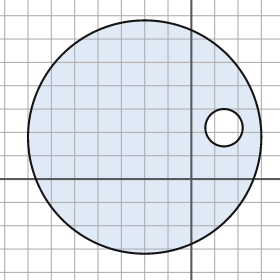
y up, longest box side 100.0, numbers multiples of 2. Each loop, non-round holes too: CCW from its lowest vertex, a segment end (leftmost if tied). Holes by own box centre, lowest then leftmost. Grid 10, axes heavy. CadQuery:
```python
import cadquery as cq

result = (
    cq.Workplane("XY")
    .moveTo(-20.0, 18.0)
    .circle(50.0)
    .moveTo(14.0, 22.0)
    .circle(8.0)
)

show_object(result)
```